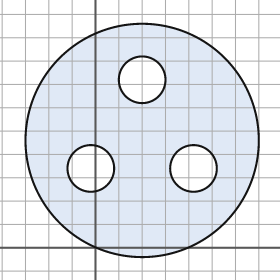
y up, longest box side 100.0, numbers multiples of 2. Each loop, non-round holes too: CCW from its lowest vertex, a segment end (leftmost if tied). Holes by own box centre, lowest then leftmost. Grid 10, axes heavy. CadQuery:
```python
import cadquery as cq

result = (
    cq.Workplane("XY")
    .moveTo(20.0, 46.0)
    .circle(50.0)
    .moveTo(-2.0, 34.0)
    .circle(10.0)
    .moveTo(42.0, 34.0)
    .circle(10.0)
    .moveTo(20.0, 72.0)
    .circle(10.0)
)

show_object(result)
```